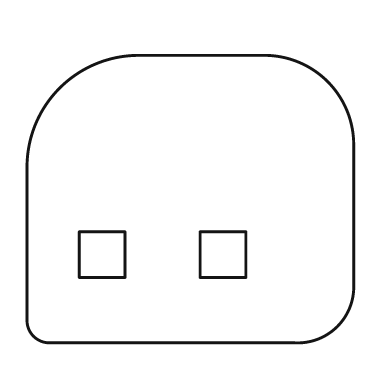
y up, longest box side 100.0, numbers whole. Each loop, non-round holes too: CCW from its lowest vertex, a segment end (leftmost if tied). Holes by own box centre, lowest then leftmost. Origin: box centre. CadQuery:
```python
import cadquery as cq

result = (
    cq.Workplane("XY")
    .moveTo(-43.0, -44.0)
    .lineTo(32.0, -44.0)
    .threePointArc((45.0, -39.0), (50.0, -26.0))
    .lineTo(50.0, 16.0)
    .threePointArc((42.0, 36.0), (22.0, 44.0))
    .lineTo(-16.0, 44.0)
    .threePointArc((-40.0, 34.0), (-50.0, 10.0))
    .lineTo(-50.0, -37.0)
    .threePointArc((-48.0, -42.0), (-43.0, -44.0))
    .close()
    .moveTo(-34.0, -24.0)
    .lineTo(-20.0, -24.0)
    .lineTo(-20.0, -10.0)
    .lineTo(-34.0, -10.0)
    .close()
    .moveTo(3.0, -24.0)
    .lineTo(17.0, -24.0)
    .lineTo(17.0, -10.0)
    .lineTo(3.0, -10.0)
    .close()
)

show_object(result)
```